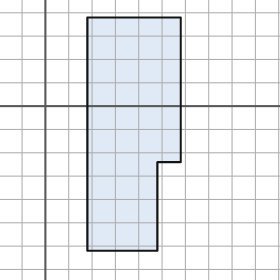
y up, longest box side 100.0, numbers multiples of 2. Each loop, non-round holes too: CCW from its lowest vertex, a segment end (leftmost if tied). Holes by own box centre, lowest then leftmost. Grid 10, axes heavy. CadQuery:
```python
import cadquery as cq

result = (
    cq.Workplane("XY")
    .moveTo(18.0, -62.0)
    .lineTo(48.0, -62.0)
    .lineTo(48.0, -24.0)
    .lineTo(58.0, -24.0)
    .lineTo(58.0, 38.0)
    .lineTo(18.0, 38.0)
    .close()
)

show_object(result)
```